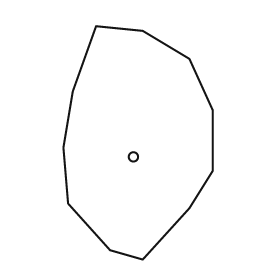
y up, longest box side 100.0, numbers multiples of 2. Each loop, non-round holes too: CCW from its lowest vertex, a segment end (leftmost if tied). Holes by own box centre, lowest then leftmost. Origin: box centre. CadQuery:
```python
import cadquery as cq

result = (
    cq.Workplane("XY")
    .moveTo(2.0, -50.0)
    .lineTo(22.0, -28.0)
    .lineTo(32.0, -12.0)
    .lineTo(32.0, 14.0)
    .lineTo(22.0, 36.0)
    .lineTo(2.0, 48.0)
    .lineTo(-18.0, 50.0)
    .lineTo(-28.0, 22.0)
    .lineTo(-32.0, -2.0)
    .lineTo(-30.0, -26.0)
    .lineTo(-12.0, -46.0)
    .close()
    .moveTo(-2.0, -6.0)
    .circle(2.0)
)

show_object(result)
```